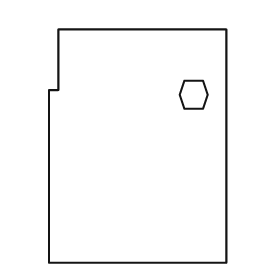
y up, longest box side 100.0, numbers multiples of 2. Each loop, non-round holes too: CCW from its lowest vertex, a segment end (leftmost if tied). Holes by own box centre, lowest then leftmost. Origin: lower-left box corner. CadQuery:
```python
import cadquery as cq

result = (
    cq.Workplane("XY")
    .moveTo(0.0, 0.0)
    .lineTo(76.0, 0.0)
    .lineTo(76.0, 100.0)
    .lineTo(4.0, 100.0)
    .lineTo(4.0, 74.0)
    .lineTo(0.0, 74.0)
    .close()
    .moveTo(58.0, 66.0)
    .lineTo(66.0, 66.0)
    .lineTo(68.0, 72.0)
    .lineTo(66.0, 78.0)
    .lineTo(58.0, 78.0)
    .lineTo(56.0, 72.0)
    .close()
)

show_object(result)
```